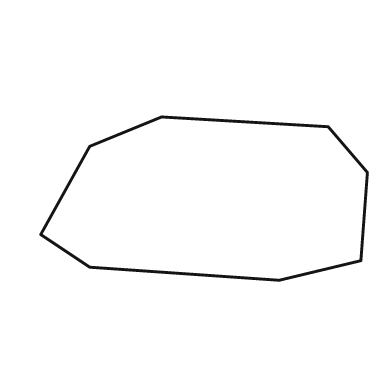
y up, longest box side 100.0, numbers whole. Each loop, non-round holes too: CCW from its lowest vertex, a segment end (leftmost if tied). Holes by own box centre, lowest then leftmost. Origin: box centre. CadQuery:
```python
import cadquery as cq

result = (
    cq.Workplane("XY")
    .moveTo(23.0, -25.0)
    .lineTo(48.0, -19.0)
    .lineTo(50.0, 8.0)
    .lineTo(38.0, 22.0)
    .lineTo(-13.0, 25.0)
    .lineTo(-35.0, 16.0)
    .lineTo(-50.0, -11.0)
    .lineTo(-35.0, -21.0)
    .close()
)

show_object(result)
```